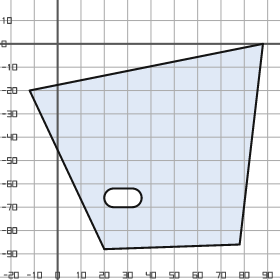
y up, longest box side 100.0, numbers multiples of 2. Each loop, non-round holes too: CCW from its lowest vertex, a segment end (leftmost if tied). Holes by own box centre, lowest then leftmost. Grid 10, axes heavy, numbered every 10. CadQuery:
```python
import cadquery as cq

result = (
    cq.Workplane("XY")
    .moveTo(20.0, -88.0)
    .lineTo(78.0, -86.0)
    .lineTo(88.0, 0.0)
    .lineTo(-12.0, -20.0)
    .close()
    .moveTo(24.0, -70.0)
    .lineTo(32.0, -70.0)
    .threePointArc((36.0, -66.0), (32.0, -62.0))
    .lineTo(24.0, -62.0)
    .threePointArc((20.0, -66.0), (24.0, -70.0))
    .close()
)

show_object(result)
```